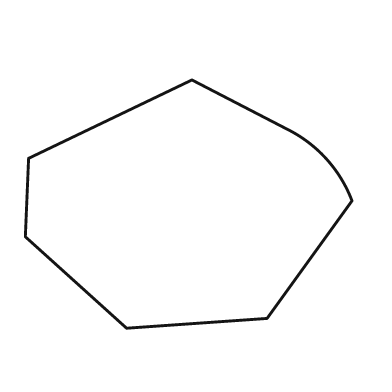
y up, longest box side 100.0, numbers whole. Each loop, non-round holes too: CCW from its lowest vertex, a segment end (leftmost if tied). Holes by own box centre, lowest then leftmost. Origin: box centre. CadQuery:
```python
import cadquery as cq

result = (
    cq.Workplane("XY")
    .moveTo(-19.0, -38.0)
    .lineTo(24.0, -35.0)
    .lineTo(50.0, 1.0)
    .threePointArc((42.0, 14.0), (30.0, 23.0))
    .lineTo(1.0, 38.0)
    .lineTo(-49.0, 14.0)
    .lineTo(-50.0, -10.0)
    .close()
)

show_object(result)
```